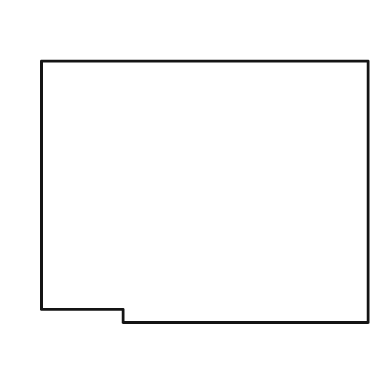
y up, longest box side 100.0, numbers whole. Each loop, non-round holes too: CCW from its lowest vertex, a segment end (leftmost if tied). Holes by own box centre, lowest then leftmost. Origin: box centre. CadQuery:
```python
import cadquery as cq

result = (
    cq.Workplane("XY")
    .moveTo(-25.0, -40.0)
    .lineTo(50.0, -40.0)
    .lineTo(50.0, 40.0)
    .lineTo(-50.0, 40.0)
    .lineTo(-50.0, -36.0)
    .lineTo(-25.0, -36.0)
    .close()
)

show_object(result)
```